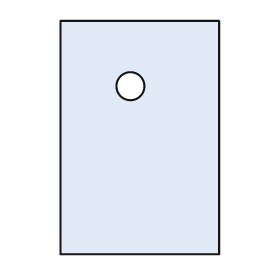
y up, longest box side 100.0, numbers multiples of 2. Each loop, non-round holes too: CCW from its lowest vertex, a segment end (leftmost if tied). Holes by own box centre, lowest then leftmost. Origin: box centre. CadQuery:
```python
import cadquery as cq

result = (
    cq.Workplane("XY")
    .moveTo(-34.0, -50.0)
    .lineTo(34.0, -50.0)
    .lineTo(34.0, 50.0)
    .lineTo(-34.0, 50.0)
    .close()
    .moveTo(-4.0, 22.0)
    .circle(6.0)
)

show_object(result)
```